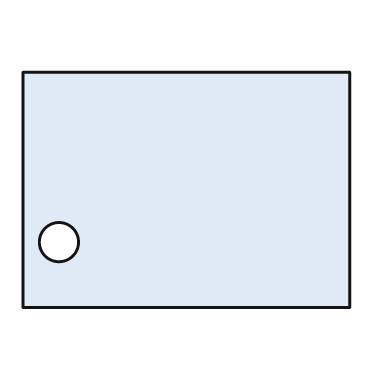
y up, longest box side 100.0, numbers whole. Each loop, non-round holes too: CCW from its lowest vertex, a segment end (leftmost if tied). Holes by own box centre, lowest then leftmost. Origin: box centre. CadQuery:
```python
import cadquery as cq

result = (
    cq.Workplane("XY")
    .moveTo(-50.0, -36.0)
    .lineTo(50.0, -36.0)
    .lineTo(50.0, 36.0)
    .lineTo(-50.0, 36.0)
    .close()
    .moveTo(-39.0, -16.0)
    .circle(6.0)
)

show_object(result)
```